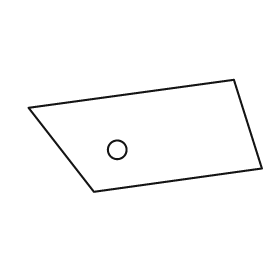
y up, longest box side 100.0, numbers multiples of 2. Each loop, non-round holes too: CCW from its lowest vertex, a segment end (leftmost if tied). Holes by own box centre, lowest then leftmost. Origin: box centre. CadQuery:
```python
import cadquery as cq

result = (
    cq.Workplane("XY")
    .moveTo(-22.0, -24.0)
    .lineTo(50.0, -14.0)
    .lineTo(38.0, 24.0)
    .lineTo(-50.0, 12.0)
    .close()
    .moveTo(-12.0, -6.0)
    .circle(4.0)
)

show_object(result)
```